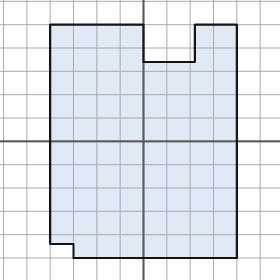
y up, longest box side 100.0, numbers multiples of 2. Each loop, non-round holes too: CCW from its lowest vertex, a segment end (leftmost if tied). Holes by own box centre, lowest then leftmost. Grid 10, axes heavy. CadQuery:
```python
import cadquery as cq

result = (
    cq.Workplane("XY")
    .moveTo(-30.0, -50.0)
    .lineTo(40.0, -50.0)
    .lineTo(40.0, 50.0)
    .lineTo(22.0, 50.0)
    .lineTo(22.0, 34.0)
    .lineTo(0.0, 34.0)
    .lineTo(0.0, 50.0)
    .lineTo(-40.0, 50.0)
    .lineTo(-40.0, -44.0)
    .lineTo(-30.0, -44.0)
    .close()
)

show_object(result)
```